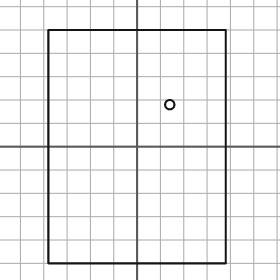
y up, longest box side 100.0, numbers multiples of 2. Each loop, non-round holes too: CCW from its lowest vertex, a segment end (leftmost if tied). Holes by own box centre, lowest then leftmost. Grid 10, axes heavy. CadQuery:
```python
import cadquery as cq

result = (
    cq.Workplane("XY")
    .moveTo(-38.0, -50.0)
    .lineTo(38.0, -50.0)
    .lineTo(38.0, 50.0)
    .lineTo(-38.0, 50.0)
    .close()
    .moveTo(14.0, 18.0)
    .circle(2.0)
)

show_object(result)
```